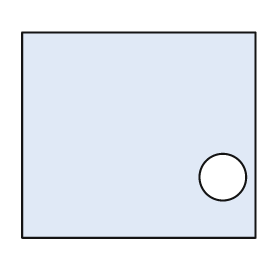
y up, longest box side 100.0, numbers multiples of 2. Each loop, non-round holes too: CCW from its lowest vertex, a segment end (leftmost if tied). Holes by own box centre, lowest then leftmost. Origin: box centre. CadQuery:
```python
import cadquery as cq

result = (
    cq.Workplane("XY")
    .moveTo(-50.0, -44.0)
    .lineTo(50.0, -44.0)
    .lineTo(50.0, 44.0)
    .lineTo(-50.0, 44.0)
    .close()
    .moveTo(36.0, -18.0)
    .circle(10.0)
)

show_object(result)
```